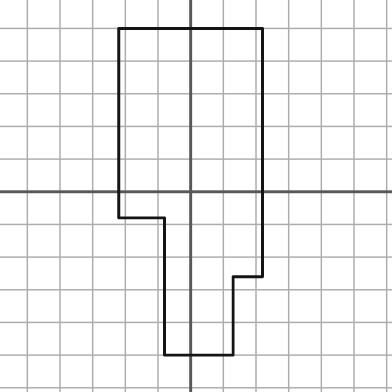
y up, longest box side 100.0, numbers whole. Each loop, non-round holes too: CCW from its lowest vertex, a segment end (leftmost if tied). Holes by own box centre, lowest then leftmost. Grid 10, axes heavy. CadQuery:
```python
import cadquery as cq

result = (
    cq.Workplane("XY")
    .moveTo(-8.0, -50.0)
    .lineTo(13.0, -50.0)
    .lineTo(13.0, -26.0)
    .lineTo(22.0, -26.0)
    .lineTo(22.0, 50.0)
    .lineTo(-22.0, 50.0)
    .lineTo(-22.0, -8.0)
    .lineTo(-8.0, -8.0)
    .close()
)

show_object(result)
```